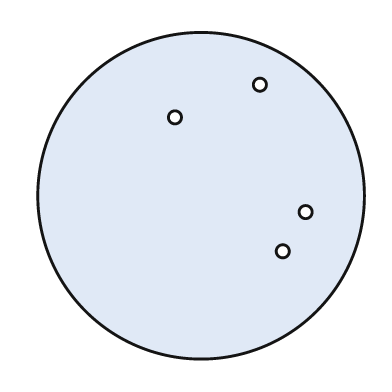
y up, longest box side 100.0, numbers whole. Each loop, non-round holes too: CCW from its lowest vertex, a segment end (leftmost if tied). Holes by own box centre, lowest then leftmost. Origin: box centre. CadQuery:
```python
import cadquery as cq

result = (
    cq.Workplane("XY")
    .moveTo(0.0, 0.0)
    .circle(50.0)
    .moveTo(25.0, -17.0)
    .circle(2.0)
    .moveTo(32.0, -5.0)
    .circle(2.0)
    .moveTo(-8.0, 24.0)
    .circle(2.0)
    .moveTo(18.0, 34.0)
    .circle(2.0)
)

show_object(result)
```